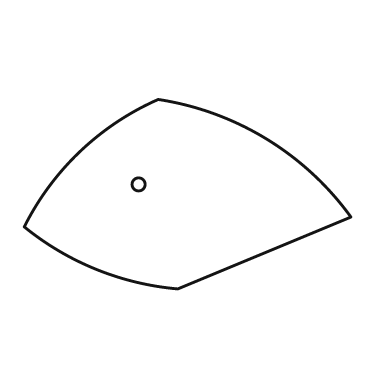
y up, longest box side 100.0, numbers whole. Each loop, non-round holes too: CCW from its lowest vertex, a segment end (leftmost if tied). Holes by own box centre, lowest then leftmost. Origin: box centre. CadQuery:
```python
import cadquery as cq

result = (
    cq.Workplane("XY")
    .moveTo(-3.0, -29.0)
    .lineTo(50.0, -7.0)
    .threePointArc((24.0, 17.0), (-9.0, 29.0))
    .threePointArc((-33.0, 13.0), (-50.0, -10.0))
    .threePointArc((-28.0, -23.0), (-3.0, -29.0))
    .close()
    .moveTo(-15.0, 3.0)
    .circle(2.0)
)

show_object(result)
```